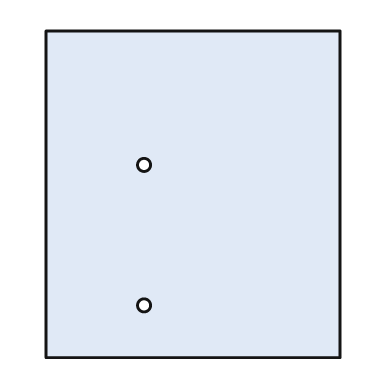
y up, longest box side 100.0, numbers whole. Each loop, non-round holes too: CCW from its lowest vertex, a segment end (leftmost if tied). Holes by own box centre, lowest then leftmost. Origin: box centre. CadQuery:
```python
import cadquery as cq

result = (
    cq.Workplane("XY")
    .moveTo(-45.0, -50.0)
    .lineTo(45.0, -50.0)
    .lineTo(45.0, 50.0)
    .lineTo(-45.0, 50.0)
    .close()
    .moveTo(-15.0, -34.0)
    .circle(2.0)
    .moveTo(-15.0, 9.0)
    .circle(2.0)
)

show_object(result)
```